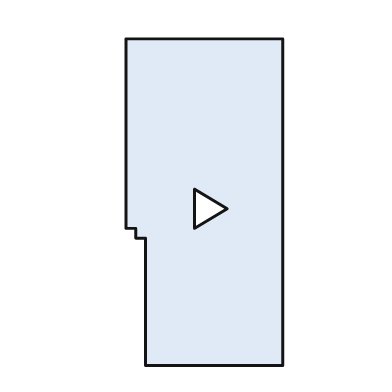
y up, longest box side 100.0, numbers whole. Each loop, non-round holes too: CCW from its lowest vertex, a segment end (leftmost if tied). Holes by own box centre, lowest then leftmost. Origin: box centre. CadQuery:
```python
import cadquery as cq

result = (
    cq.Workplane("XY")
    .moveTo(-18.0, -50.0)
    .lineTo(24.0, -50.0)
    .lineTo(24.0, 50.0)
    .lineTo(-24.0, 50.0)
    .lineTo(-24.0, -8.0)
    .lineTo(-21.0, -8.0)
    .lineTo(-21.0, -11.0)
    .lineTo(-18.0, -11.0)
    .close()
    .moveTo(-3.0, -8.0)
    .lineTo(7.0, -2.0)
    .lineTo(-3.0, 4.0)
    .close()
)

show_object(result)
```